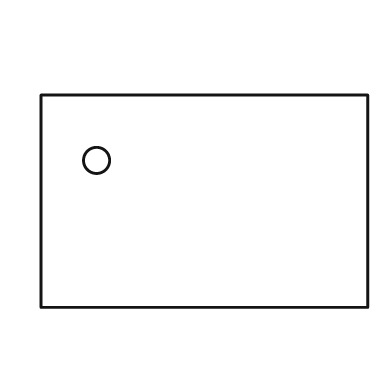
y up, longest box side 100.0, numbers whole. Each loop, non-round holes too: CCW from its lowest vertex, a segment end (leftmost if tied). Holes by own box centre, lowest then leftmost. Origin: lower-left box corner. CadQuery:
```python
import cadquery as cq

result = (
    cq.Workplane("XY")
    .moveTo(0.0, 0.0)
    .lineTo(100.0, 0.0)
    .lineTo(100.0, 65.0)
    .lineTo(0.0, 65.0)
    .close()
    .moveTo(17.0, 45.0)
    .circle(4.0)
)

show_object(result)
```